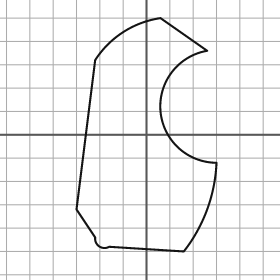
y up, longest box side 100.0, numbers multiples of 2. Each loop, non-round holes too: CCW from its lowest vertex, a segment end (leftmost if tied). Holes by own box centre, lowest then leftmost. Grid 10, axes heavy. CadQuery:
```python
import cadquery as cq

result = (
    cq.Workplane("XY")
    .moveTo(16.0, -50.0)
    .threePointArc((26.0, -32.0), (30.0, -12.0))
    .threePointArc((6.0, 10.0), (26.0, 36.0))
    .lineTo(6.0, 50.0)
    .threePointArc((-10.0, 44.0), (-22.0, 32.0))
    .lineTo(-30.0, -32.0)
    .lineTo(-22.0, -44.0)
    .threePointArc((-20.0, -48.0), (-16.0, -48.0))
    .close()
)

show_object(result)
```